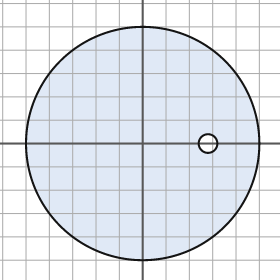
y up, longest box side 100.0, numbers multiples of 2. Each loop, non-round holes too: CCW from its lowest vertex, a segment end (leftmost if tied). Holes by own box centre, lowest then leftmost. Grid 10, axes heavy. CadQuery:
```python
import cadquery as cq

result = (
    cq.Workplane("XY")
    .moveTo(0.0, 0.0)
    .circle(50.0)
    .moveTo(28.0, 0.0)
    .circle(4.0)
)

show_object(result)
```